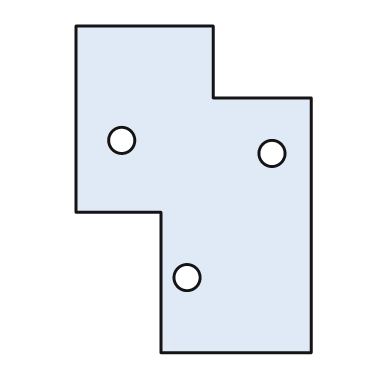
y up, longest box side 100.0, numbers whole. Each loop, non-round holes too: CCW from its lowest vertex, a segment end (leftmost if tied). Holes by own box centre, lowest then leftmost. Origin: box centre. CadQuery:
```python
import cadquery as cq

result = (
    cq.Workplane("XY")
    .moveTo(-10.0, -50.0)
    .lineTo(36.0, -50.0)
    .lineTo(36.0, 28.0)
    .lineTo(6.0, 28.0)
    .lineTo(6.0, 50.0)
    .lineTo(-36.0, 50.0)
    .lineTo(-36.0, -7.0)
    .lineTo(-10.0, -7.0)
    .close()
    .moveTo(-2.0, -27.0)
    .circle(4.0)
    .moveTo(24.0, 11.0)
    .circle(4.0)
    .moveTo(-22.0, 15.0)
    .circle(4.0)
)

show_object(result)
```